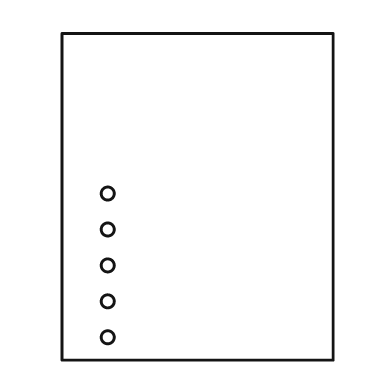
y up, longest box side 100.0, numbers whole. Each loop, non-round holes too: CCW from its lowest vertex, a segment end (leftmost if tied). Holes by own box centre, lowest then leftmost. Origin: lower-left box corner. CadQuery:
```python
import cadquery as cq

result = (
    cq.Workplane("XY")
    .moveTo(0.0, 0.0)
    .lineTo(83.0, 0.0)
    .lineTo(83.0, 100.0)
    .lineTo(0.0, 100.0)
    .close()
    .moveTo(14.0, 7.0)
    .circle(2.0)
    .moveTo(14.0, 18.0)
    .circle(2.0)
    .moveTo(14.0, 29.0)
    .circle(2.0)
    .moveTo(14.0, 40.0)
    .circle(2.0)
    .moveTo(14.0, 51.0)
    .circle(2.0)
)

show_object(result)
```